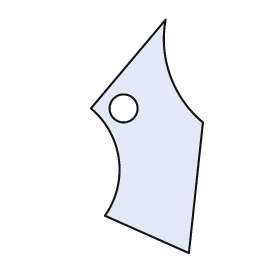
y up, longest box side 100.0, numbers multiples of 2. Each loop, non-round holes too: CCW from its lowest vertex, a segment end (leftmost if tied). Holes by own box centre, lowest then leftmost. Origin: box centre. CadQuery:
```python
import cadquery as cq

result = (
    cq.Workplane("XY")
    .moveTo(18.0, -50.0)
    .lineTo(24.0, 6.0)
    .threePointArc((10.0, 26.0), (8.0, 50.0))
    .lineTo(-24.0, 12.0)
    .threePointArc((-12.0, -10.0), (-18.0, -34.0))
    .close()
    .moveTo(-10.0, 12.0)
    .circle(6.0)
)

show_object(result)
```